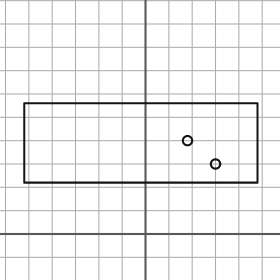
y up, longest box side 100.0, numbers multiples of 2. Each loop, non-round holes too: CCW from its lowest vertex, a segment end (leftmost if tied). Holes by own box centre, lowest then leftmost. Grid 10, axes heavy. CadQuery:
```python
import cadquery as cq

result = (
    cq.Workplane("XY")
    .moveTo(-52.0, 22.0)
    .lineTo(48.0, 22.0)
    .lineTo(48.0, 56.0)
    .lineTo(-52.0, 56.0)
    .close()
    .moveTo(30.0, 30.0)
    .circle(2.0)
    .moveTo(18.0, 40.0)
    .circle(2.0)
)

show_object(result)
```